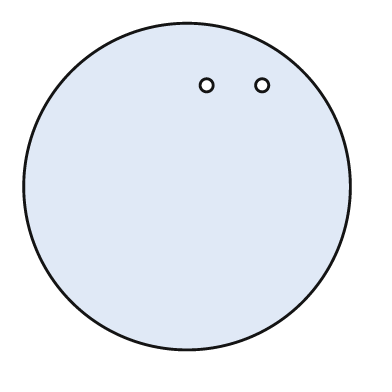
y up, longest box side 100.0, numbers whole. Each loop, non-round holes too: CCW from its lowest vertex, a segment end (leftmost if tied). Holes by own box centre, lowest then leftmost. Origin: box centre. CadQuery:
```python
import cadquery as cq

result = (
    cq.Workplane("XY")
    .moveTo(0.0, 0.0)
    .circle(50.0)
    .moveTo(6.0, 31.0)
    .circle(2.0)
    .moveTo(23.0, 31.0)
    .circle(2.0)
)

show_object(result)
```